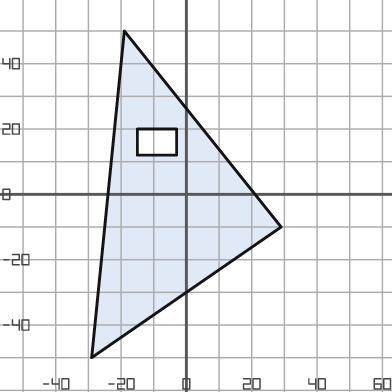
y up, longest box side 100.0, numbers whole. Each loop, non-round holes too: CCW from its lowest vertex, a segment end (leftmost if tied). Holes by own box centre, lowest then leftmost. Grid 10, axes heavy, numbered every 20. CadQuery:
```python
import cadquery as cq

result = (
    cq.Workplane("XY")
    .moveTo(-29.0, -50.0)
    .lineTo(29.0, -10.0)
    .lineTo(-19.0, 50.0)
    .close()
    .moveTo(-15.0, 12.0)
    .lineTo(-3.0, 12.0)
    .lineTo(-3.0, 20.0)
    .lineTo(-15.0, 20.0)
    .close()
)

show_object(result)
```